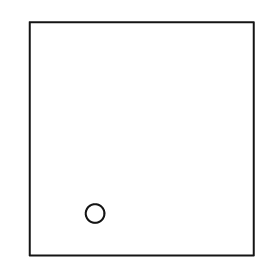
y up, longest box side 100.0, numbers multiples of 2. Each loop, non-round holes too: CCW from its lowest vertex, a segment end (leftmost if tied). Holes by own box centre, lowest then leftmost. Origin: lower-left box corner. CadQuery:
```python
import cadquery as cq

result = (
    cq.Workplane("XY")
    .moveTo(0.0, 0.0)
    .lineTo(96.0, 0.0)
    .lineTo(96.0, 100.0)
    .lineTo(0.0, 100.0)
    .close()
    .moveTo(28.0, 18.0)
    .circle(4.0)
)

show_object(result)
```